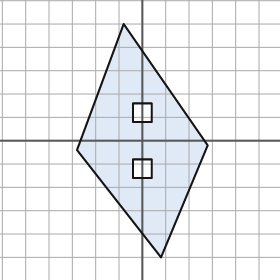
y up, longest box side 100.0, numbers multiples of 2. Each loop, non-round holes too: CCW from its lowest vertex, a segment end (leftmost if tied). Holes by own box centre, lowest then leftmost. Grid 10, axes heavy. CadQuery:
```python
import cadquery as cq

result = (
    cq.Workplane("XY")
    .moveTo(8.0, -50.0)
    .lineTo(28.0, -2.0)
    .lineTo(-8.0, 50.0)
    .lineTo(-28.0, -4.0)
    .close()
    .moveTo(-4.0, -16.0)
    .lineTo(4.0, -16.0)
    .lineTo(4.0, -8.0)
    .lineTo(-4.0, -8.0)
    .close()
    .moveTo(-4.0, 8.0)
    .lineTo(4.0, 8.0)
    .lineTo(4.0, 16.0)
    .lineTo(-4.0, 16.0)
    .close()
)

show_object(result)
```